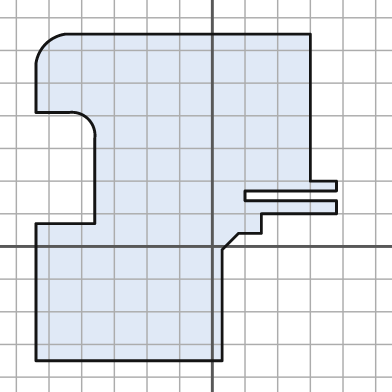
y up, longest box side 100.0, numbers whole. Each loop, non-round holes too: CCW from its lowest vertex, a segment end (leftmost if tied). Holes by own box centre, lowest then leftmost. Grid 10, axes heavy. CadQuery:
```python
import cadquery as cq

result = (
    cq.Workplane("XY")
    .moveTo(-54.0, -35.0)
    .lineTo(3.0, -35.0)
    .lineTo(3.0, -1.0)
    .lineTo(8.0, 4.0)
    .lineTo(15.0, 4.0)
    .lineTo(15.0, 10.0)
    .lineTo(38.0, 10.0)
    .lineTo(38.0, 14.0)
    .lineTo(10.0, 14.0)
    .lineTo(10.0, 17.0)
    .lineTo(38.0, 17.0)
    .lineTo(38.0, 20.0)
    .lineTo(30.0, 20.0)
    .lineTo(30.0, 65.0)
    .lineTo(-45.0, 65.0)
    .threePointArc((-51.0, 62.0), (-54.0, 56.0))
    .lineTo(-54.0, 41.0)
    .lineTo(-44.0, 41.0)
    .threePointArc((-38.0, 39.0), (-36.0, 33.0))
    .lineTo(-36.0, 7.0)
    .lineTo(-54.0, 7.0)
    .close()
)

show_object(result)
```